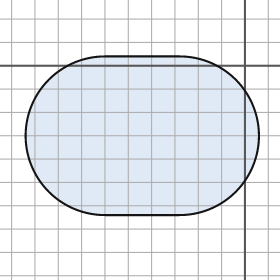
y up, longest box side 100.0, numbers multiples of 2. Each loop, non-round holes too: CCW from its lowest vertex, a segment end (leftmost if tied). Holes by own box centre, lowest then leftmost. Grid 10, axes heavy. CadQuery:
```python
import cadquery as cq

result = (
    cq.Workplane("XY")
    .moveTo(-60.0, -64.0)
    .lineTo(-28.0, -64.0)
    .threePointArc((6.0, -30.0), (-28.0, 4.0))
    .lineTo(-60.0, 4.0)
    .threePointArc((-94.0, -30.0), (-60.0, -64.0))
    .close()
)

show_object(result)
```